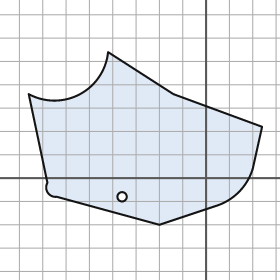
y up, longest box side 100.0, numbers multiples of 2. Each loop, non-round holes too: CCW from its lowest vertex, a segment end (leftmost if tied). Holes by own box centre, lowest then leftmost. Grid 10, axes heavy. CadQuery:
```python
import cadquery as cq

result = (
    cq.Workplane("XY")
    .moveTo(-20.0, -20.0)
    .lineTo(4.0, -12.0)
    .threePointArc((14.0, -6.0), (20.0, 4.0))
    .lineTo(24.0, 22.0)
    .lineTo(-14.0, 36.0)
    .lineTo(-42.0, 54.0)
    .threePointArc((-54.0, 36.0), (-76.0, 36.0))
    .lineTo(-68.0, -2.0)
    .threePointArc((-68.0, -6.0), (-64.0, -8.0))
    .close()
    .moveTo(-36.0, -8.0)
    .circle(2.0)
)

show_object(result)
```